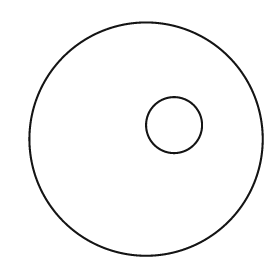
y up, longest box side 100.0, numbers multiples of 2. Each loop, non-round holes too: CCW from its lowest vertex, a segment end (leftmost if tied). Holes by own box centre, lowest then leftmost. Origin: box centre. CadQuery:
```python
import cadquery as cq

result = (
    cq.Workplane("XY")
    .moveTo(0.0, 0.0)
    .circle(50.0)
    .moveTo(12.0, 6.0)
    .circle(12.0)
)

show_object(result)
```